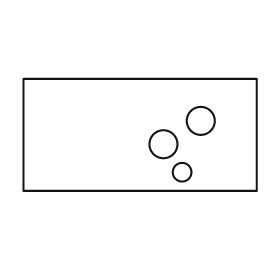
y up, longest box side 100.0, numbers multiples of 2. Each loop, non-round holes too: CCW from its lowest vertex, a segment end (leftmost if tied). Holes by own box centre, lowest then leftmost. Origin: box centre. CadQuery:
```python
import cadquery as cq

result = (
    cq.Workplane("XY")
    .moveTo(-50.0, -24.0)
    .lineTo(50.0, -24.0)
    .lineTo(50.0, 24.0)
    .lineTo(-50.0, 24.0)
    .close()
    .moveTo(18.0, -16.0)
    .circle(4.0)
    .moveTo(10.0, -4.0)
    .circle(6.0)
    .moveTo(26.0, 6.0)
    .circle(6.0)
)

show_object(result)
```